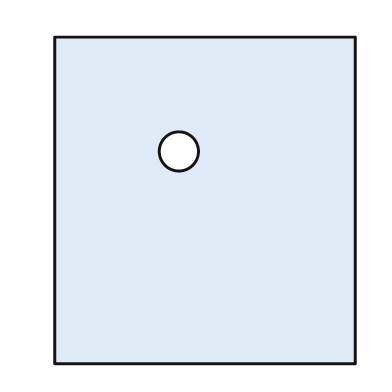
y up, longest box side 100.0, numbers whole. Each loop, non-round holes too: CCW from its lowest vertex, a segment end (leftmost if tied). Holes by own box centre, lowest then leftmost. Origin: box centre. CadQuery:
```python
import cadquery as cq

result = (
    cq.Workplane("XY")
    .moveTo(-46.0, -50.0)
    .lineTo(46.0, -50.0)
    .lineTo(46.0, 50.0)
    .lineTo(-46.0, 50.0)
    .close()
    .moveTo(-8.0, 15.0)
    .circle(6.0)
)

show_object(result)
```